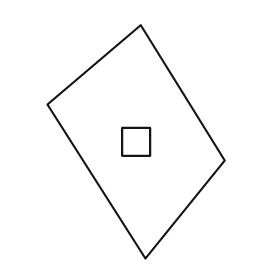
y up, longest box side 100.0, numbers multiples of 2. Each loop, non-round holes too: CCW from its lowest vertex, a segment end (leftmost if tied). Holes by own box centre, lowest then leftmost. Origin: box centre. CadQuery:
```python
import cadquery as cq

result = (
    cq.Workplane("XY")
    .moveTo(4.0, -50.0)
    .lineTo(38.0, -8.0)
    .lineTo(2.0, 50.0)
    .lineTo(-38.0, 16.0)
    .close()
    .moveTo(-6.0, -6.0)
    .lineTo(6.0, -6.0)
    .lineTo(6.0, 6.0)
    .lineTo(-6.0, 6.0)
    .close()
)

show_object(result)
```